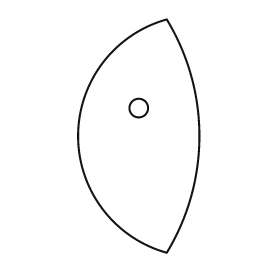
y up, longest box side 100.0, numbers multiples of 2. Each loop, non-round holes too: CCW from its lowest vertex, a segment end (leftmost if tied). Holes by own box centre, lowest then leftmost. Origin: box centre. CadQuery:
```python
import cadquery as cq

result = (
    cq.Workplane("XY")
    .moveTo(12.0, -50.0)
    .threePointArc((26.0, 0.0), (12.0, 50.0))
    .threePointArc((-26.0, 0.0), (12.0, -50.0))
    .close()
    .moveTo(0.0, 12.0)
    .circle(4.0)
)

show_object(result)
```